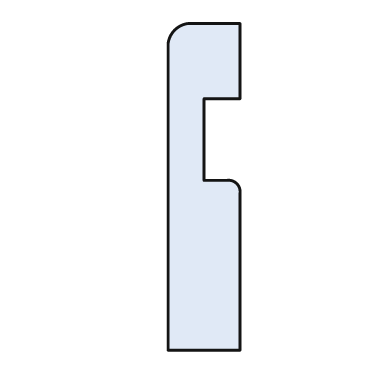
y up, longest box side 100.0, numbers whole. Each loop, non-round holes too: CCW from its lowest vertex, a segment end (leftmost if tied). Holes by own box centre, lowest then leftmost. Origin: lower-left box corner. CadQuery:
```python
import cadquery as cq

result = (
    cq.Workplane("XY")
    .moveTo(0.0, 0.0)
    .lineTo(22.0, 0.0)
    .lineTo(22.0, 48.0)
    .threePointArc((21.0, 51.0), (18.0, 52.0))
    .lineTo(11.0, 52.0)
    .lineTo(11.0, 77.0)
    .lineTo(22.0, 77.0)
    .lineTo(22.0, 100.0)
    .lineTo(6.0, 100.0)
    .threePointArc((2.0, 98.0), (0.0, 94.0))
    .close()
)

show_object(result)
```